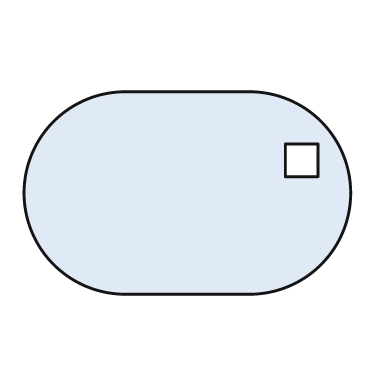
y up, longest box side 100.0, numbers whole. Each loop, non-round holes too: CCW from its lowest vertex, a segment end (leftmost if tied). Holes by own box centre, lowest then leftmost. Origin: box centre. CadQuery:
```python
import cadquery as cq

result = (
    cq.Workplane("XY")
    .moveTo(-19.0, -31.0)
    .lineTo(19.0, -31.0)
    .threePointArc((50.0, 0.0), (19.0, 31.0))
    .lineTo(-19.0, 31.0)
    .threePointArc((-50.0, 0.0), (-19.0, -31.0))
    .close()
    .moveTo(30.0, 5.0)
    .lineTo(40.0, 5.0)
    .lineTo(40.0, 15.0)
    .lineTo(30.0, 15.0)
    .close()
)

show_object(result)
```